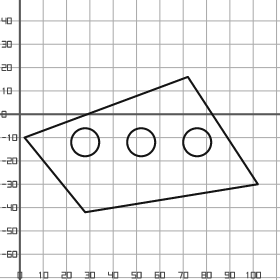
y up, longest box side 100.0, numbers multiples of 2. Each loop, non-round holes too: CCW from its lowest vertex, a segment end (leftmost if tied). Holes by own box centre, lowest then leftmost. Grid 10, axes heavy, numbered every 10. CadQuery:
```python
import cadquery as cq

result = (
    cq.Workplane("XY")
    .moveTo(28.0, -42.0)
    .lineTo(102.0, -30.0)
    .lineTo(72.0, 16.0)
    .lineTo(2.0, -10.0)
    .close()
    .moveTo(28.0, -12.0)
    .circle(6.0)
    .moveTo(52.0, -12.0)
    .circle(6.0)
    .moveTo(76.0, -12.0)
    .circle(6.0)
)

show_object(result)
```